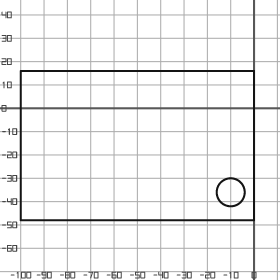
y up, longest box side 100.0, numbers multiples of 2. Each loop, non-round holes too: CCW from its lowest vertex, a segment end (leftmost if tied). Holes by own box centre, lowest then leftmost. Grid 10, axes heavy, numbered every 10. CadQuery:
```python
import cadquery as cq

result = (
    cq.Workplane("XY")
    .moveTo(-100.0, -48.0)
    .lineTo(0.0, -48.0)
    .lineTo(0.0, 16.0)
    .lineTo(-100.0, 16.0)
    .close()
    .moveTo(-10.0, -36.0)
    .circle(6.0)
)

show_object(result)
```